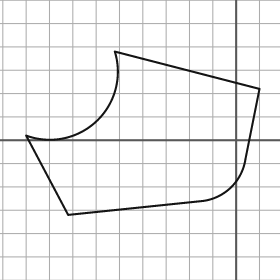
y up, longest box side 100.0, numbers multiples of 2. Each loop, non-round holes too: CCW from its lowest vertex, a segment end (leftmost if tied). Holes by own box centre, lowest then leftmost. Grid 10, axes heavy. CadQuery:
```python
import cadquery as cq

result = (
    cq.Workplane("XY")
    .moveTo(-72.0, -32.0)
    .lineTo(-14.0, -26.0)
    .threePointArc((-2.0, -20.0), (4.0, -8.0))
    .lineTo(10.0, 22.0)
    .lineTo(-52.0, 38.0)
    .threePointArc((-60.0, 8.0), (-90.0, 2.0))
    .close()
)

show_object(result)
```